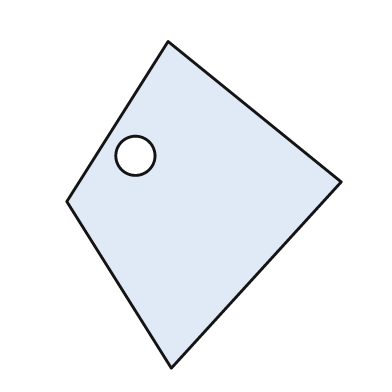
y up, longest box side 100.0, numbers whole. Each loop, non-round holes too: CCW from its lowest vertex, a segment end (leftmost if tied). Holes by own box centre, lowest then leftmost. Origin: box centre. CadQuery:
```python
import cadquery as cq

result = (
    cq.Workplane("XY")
    .moveTo(-10.0, -50.0)
    .lineTo(42.0, 7.0)
    .lineTo(-11.0, 50.0)
    .lineTo(-42.0, 1.0)
    .close()
    .moveTo(-21.0, 15.0)
    .circle(6.0)
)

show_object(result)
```